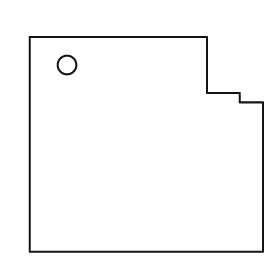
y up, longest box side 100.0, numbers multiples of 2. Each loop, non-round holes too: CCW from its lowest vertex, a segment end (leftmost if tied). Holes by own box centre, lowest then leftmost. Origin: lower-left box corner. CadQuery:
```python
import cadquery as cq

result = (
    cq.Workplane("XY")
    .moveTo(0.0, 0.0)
    .lineTo(100.0, 0.0)
    .lineTo(100.0, 64.0)
    .lineTo(90.0, 64.0)
    .lineTo(90.0, 68.0)
    .lineTo(76.0, 68.0)
    .lineTo(76.0, 92.0)
    .lineTo(0.0, 92.0)
    .close()
    .moveTo(16.0, 80.0)
    .circle(4.0)
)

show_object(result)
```